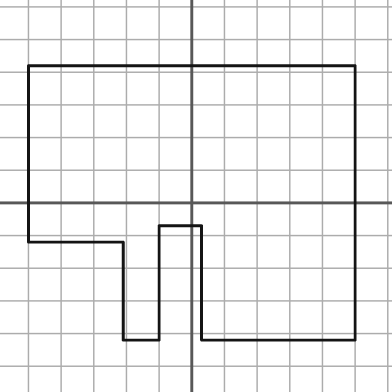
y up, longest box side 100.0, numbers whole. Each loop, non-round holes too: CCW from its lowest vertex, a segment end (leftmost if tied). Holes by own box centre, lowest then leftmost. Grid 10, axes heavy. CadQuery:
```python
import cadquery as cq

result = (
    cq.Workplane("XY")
    .moveTo(-21.0, -42.0)
    .lineTo(-10.0, -42.0)
    .lineTo(-10.0, -7.0)
    .lineTo(3.0, -7.0)
    .lineTo(3.0, -42.0)
    .lineTo(50.0, -42.0)
    .lineTo(50.0, 42.0)
    .lineTo(-50.0, 42.0)
    .lineTo(-50.0, -12.0)
    .lineTo(-21.0, -12.0)
    .close()
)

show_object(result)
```